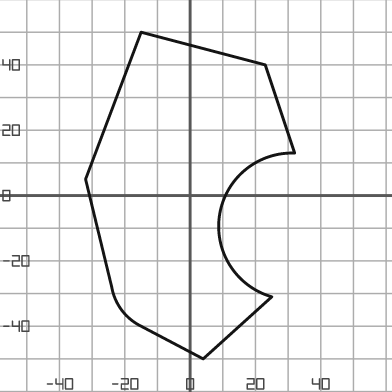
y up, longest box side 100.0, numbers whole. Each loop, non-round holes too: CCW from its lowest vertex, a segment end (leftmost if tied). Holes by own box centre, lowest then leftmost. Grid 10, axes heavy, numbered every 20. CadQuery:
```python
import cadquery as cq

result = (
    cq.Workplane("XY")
    .moveTo(4.0, -50.0)
    .lineTo(25.0, -31.0)
    .threePointArc((9.0, -6.0), (32.0, 13.0))
    .lineTo(23.0, 40.0)
    .lineTo(-15.0, 50.0)
    .lineTo(-32.0, 5.0)
    .lineTo(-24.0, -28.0)
    .threePointArc((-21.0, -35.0), (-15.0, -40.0))
    .close()
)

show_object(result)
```